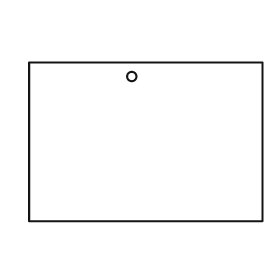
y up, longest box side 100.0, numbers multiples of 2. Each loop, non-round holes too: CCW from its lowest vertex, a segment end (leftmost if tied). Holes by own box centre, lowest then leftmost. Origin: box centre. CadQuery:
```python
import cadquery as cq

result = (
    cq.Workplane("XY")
    .moveTo(-50.0, -34.0)
    .lineTo(50.0, -34.0)
    .lineTo(50.0, 34.0)
    .lineTo(-50.0, 34.0)
    .close()
    .moveTo(-6.0, 28.0)
    .circle(2.0)
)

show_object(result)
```